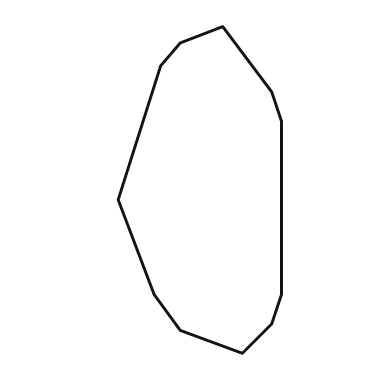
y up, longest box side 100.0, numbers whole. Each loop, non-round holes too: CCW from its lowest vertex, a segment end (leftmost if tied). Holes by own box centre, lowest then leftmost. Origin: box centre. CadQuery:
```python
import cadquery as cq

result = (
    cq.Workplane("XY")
    .moveTo(13.0, -50.0)
    .lineTo(22.0, -41.0)
    .lineTo(25.0, -32.0)
    .lineTo(25.0, 21.0)
    .lineTo(22.0, 30.0)
    .lineTo(7.0, 50.0)
    .lineTo(-6.0, 45.0)
    .lineTo(-12.0, 38.0)
    .lineTo(-25.0, -3.0)
    .lineTo(-14.0, -32.0)
    .lineTo(-6.0, -43.0)
    .close()
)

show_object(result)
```